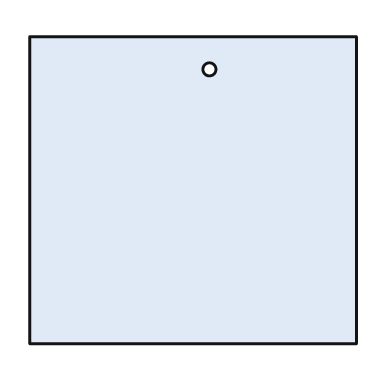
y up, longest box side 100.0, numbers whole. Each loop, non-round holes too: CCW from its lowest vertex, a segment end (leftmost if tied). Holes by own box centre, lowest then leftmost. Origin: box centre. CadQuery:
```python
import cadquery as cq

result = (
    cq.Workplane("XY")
    .moveTo(-50.0, -47.0)
    .lineTo(50.0, -47.0)
    .lineTo(50.0, 47.0)
    .lineTo(-50.0, 47.0)
    .close()
    .moveTo(5.0, 37.0)
    .circle(2.0)
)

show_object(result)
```